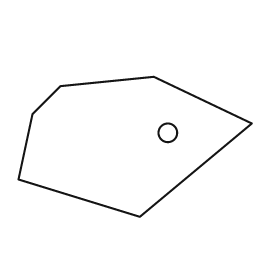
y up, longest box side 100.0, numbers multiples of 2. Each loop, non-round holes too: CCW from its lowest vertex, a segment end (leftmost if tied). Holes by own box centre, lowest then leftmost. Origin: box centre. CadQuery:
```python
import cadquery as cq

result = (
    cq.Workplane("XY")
    .moveTo(2.0, -30.0)
    .lineTo(50.0, 10.0)
    .lineTo(8.0, 30.0)
    .lineTo(-32.0, 26.0)
    .lineTo(-44.0, 14.0)
    .lineTo(-50.0, -14.0)
    .close()
    .moveTo(14.0, 6.0)
    .circle(4.0)
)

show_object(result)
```